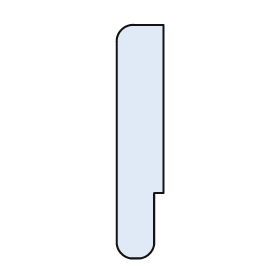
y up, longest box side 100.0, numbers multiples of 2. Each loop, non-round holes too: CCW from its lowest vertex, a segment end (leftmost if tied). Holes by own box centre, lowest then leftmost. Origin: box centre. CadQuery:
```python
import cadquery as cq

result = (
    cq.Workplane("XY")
    .moveTo(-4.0, -50.0)
    .lineTo(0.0, -50.0)
    .threePointArc((4.0, -48.0), (6.0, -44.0))
    .lineTo(6.0, -22.0)
    .lineTo(10.0, -22.0)
    .lineTo(10.0, 50.0)
    .lineTo(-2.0, 50.0)
    .threePointArc((-8.0, 48.0), (-10.0, 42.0))
    .lineTo(-10.0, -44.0)
    .threePointArc((-8.0, -48.0), (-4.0, -50.0))
    .close()
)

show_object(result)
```